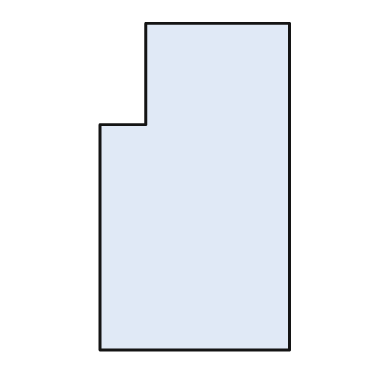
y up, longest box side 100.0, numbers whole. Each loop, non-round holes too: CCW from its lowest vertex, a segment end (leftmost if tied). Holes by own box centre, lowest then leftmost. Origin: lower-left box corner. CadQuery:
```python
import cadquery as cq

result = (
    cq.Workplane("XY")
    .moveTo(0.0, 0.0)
    .lineTo(58.0, 0.0)
    .lineTo(58.0, 100.0)
    .lineTo(14.0, 100.0)
    .lineTo(14.0, 69.0)
    .lineTo(0.0, 69.0)
    .close()
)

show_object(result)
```